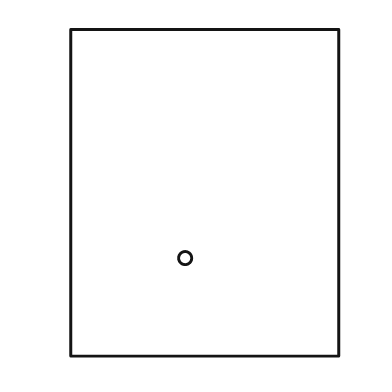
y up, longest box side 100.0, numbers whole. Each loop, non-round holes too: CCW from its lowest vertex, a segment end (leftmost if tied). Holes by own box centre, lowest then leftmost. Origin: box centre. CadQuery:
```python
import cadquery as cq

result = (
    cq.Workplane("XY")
    .moveTo(-41.0, -50.0)
    .lineTo(41.0, -50.0)
    .lineTo(41.0, 50.0)
    .lineTo(-41.0, 50.0)
    .close()
    .moveTo(-6.0, -20.0)
    .circle(2.0)
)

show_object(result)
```